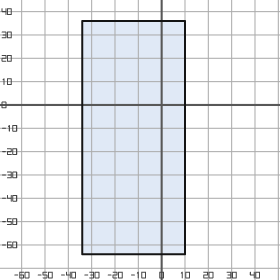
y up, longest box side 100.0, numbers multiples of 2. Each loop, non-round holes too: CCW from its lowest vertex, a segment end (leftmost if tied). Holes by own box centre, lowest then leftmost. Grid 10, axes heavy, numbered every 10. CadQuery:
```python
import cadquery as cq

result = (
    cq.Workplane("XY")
    .moveTo(-34.0, -64.0)
    .lineTo(10.0, -64.0)
    .lineTo(10.0, 36.0)
    .lineTo(-34.0, 36.0)
    .close()
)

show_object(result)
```